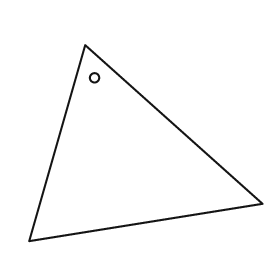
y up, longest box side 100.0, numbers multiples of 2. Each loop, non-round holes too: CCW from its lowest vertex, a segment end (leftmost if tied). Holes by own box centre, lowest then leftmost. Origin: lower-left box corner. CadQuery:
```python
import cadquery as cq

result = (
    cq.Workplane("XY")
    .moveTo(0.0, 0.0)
    .lineTo(100.0, 16.0)
    .lineTo(24.0, 84.0)
    .close()
    .moveTo(28.0, 70.0)
    .circle(2.0)
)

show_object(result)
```